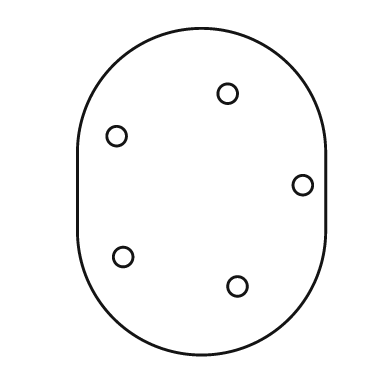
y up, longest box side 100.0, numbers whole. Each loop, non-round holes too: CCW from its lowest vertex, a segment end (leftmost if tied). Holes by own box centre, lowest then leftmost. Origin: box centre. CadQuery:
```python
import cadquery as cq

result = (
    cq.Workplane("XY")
    .moveTo(-38.0, -12.0)
    .threePointArc((0.0, -50.0), (38.0, -12.0))
    .lineTo(38.0, 12.0)
    .threePointArc((0.0, 50.0), (-38.0, 12.0))
    .close()
    .moveTo(11.0, -29.0)
    .circle(3.0)
    .moveTo(-24.0, -20.0)
    .circle(3.0)
    .moveTo(31.0, 2.0)
    .circle(3.0)
    .moveTo(-26.0, 17.0)
    .circle(3.0)
    .moveTo(8.0, 30.0)
    .circle(3.0)
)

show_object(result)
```